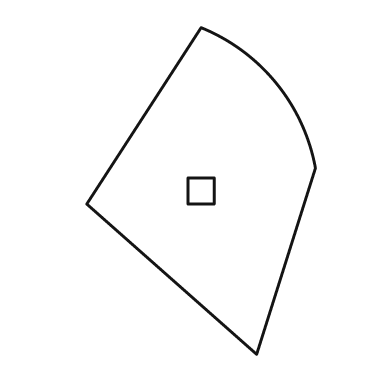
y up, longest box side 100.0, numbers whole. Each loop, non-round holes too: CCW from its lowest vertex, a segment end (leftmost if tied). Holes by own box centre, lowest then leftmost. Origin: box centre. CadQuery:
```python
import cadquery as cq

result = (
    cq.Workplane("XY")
    .moveTo(17.0, -50.0)
    .lineTo(35.0, 7.0)
    .threePointArc((23.0, 33.0), (0.0, 50.0))
    .lineTo(-35.0, -4.0)
    .close()
    .moveTo(-4.0, -4.0)
    .lineTo(4.0, -4.0)
    .lineTo(4.0, 4.0)
    .lineTo(-4.0, 4.0)
    .close()
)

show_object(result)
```